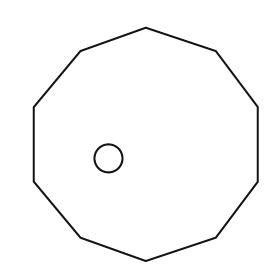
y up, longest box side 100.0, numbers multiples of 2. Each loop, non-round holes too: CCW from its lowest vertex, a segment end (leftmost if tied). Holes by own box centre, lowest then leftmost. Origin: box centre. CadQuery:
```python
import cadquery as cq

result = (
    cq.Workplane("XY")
    .moveTo(0.0, -50.0)
    .lineTo(30.0, -40.0)
    .lineTo(48.0, -16.0)
    .lineTo(48.0, 16.0)
    .lineTo(30.0, 40.0)
    .lineTo(0.0, 50.0)
    .lineTo(-28.0, 40.0)
    .lineTo(-48.0, 16.0)
    .lineTo(-48.0, -16.0)
    .lineTo(-28.0, -40.0)
    .close()
    .moveTo(-16.0, -6.0)
    .circle(6.0)
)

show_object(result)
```